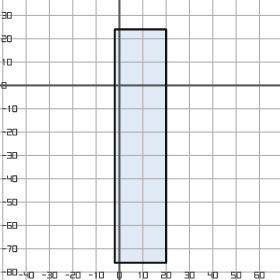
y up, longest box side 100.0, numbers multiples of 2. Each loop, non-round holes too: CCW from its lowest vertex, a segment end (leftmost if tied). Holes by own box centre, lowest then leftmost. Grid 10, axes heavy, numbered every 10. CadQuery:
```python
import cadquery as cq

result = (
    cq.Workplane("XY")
    .moveTo(-2.0, -76.0)
    .lineTo(20.0, -76.0)
    .lineTo(20.0, 24.0)
    .lineTo(-2.0, 24.0)
    .close()
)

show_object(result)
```